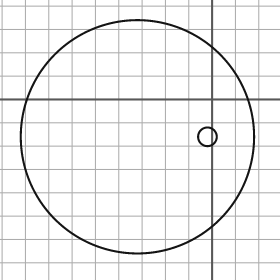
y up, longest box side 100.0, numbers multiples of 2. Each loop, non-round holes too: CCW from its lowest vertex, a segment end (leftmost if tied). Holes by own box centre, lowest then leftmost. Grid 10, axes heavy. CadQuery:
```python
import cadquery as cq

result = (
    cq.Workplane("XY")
    .moveTo(-32.0, -16.0)
    .circle(50.0)
    .moveTo(-2.0, -16.0)
    .circle(4.0)
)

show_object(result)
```